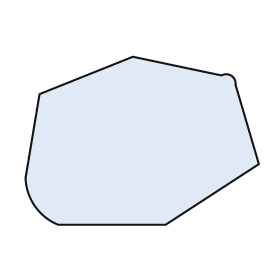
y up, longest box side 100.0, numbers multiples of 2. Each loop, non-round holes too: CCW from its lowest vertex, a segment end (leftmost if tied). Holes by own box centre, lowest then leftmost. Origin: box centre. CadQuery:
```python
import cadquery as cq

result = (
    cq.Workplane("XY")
    .moveTo(-36.0, -36.0)
    .lineTo(10.0, -36.0)
    .lineTo(50.0, -10.0)
    .lineTo(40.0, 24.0)
    .threePointArc((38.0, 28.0), (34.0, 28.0))
    .lineTo(-4.0, 36.0)
    .lineTo(-44.0, 20.0)
    .lineTo(-50.0, -16.0)
    .threePointArc((-46.0, -28.0), (-36.0, -36.0))
    .close()
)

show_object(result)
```